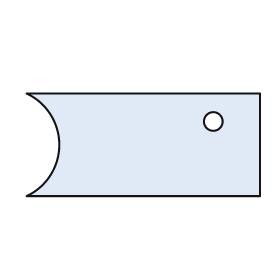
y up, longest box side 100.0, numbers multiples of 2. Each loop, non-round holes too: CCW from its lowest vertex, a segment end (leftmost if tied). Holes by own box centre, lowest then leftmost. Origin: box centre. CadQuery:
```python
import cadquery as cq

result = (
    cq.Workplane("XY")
    .moveTo(-50.0, -22.0)
    .lineTo(50.0, -22.0)
    .lineTo(50.0, 22.0)
    .lineTo(-50.0, 22.0)
    .threePointArc((-36.0, 0.0), (-50.0, -22.0))
    .close()
    .moveTo(30.0, 10.0)
    .circle(4.0)
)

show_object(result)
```